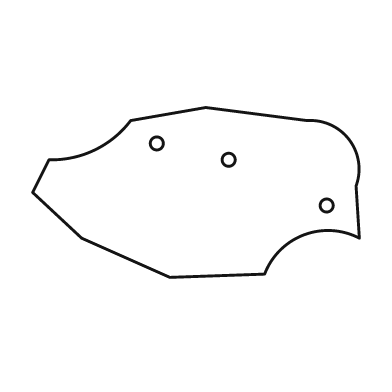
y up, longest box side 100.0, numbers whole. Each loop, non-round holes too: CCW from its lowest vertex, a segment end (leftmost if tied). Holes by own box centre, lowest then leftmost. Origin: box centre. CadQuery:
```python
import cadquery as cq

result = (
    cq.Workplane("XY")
    .moveTo(-8.0, -26.0)
    .lineTo(21.0, -25.0)
    .threePointArc((33.0, -13.0), (50.0, -14.0))
    .lineTo(49.0, 2.0)
    .threePointArc((47.0, 16.0), (34.0, 22.0))
    .lineTo(3.0, 26.0)
    .lineTo(-20.0, 22.0)
    .threePointArc((-31.0, 13.0), (-45.0, 10.0))
    .lineTo(-50.0, 0.0)
    .lineTo(-35.0, -14.0)
    .close()
    .moveTo(40.0, -4.0)
    .circle(2.0)
    .moveTo(10.0, 10.0)
    .circle(2.0)
    .moveTo(-12.0, 15.0)
    .circle(2.0)
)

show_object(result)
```